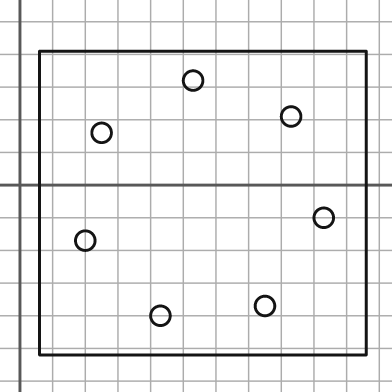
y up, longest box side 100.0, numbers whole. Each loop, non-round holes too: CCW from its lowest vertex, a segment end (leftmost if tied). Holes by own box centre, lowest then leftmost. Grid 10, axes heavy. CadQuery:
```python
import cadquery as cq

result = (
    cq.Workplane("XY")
    .moveTo(6.0, -52.0)
    .lineTo(106.0, -52.0)
    .lineTo(106.0, 41.0)
    .lineTo(6.0, 41.0)
    .close()
    .moveTo(43.0, -40.0)
    .circle(3.0)
    .moveTo(75.0, -37.0)
    .circle(3.0)
    .moveTo(20.0, -17.0)
    .circle(3.0)
    .moveTo(93.0, -10.0)
    .circle(3.0)
    .moveTo(25.0, 16.0)
    .circle(3.0)
    .moveTo(83.0, 21.0)
    .circle(3.0)
    .moveTo(53.0, 32.0)
    .circle(3.0)
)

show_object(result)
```